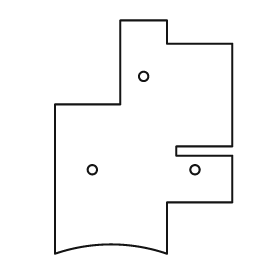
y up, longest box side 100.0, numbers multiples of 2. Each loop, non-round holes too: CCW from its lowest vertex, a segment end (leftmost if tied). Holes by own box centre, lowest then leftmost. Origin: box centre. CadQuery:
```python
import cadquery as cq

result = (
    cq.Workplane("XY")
    .moveTo(-38.0, -50.0)
    .threePointArc((-14.0, -46.0), (10.0, -50.0))
    .lineTo(10.0, -28.0)
    .lineTo(38.0, -28.0)
    .lineTo(38.0, -8.0)
    .lineTo(14.0, -8.0)
    .lineTo(14.0, -4.0)
    .lineTo(38.0, -4.0)
    .lineTo(38.0, 40.0)
    .lineTo(10.0, 40.0)
    .lineTo(10.0, 50.0)
    .lineTo(-10.0, 50.0)
    .lineTo(-10.0, 14.0)
    .lineTo(-38.0, 14.0)
    .close()
    .moveTo(-22.0, -14.0)
    .circle(2.0)
    .moveTo(22.0, -14.0)
    .circle(2.0)
    .moveTo(0.0, 26.0)
    .circle(2.0)
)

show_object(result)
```